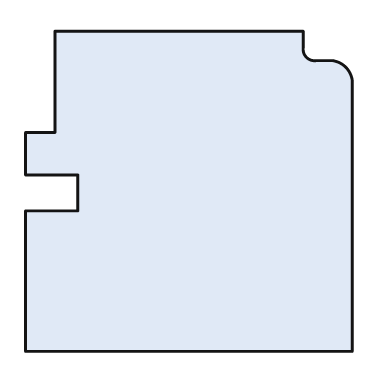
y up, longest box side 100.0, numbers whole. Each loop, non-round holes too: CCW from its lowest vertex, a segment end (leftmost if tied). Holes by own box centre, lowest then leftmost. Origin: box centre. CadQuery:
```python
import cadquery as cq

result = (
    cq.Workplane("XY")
    .moveTo(-50.0, -49.0)
    .lineTo(50.0, -49.0)
    .lineTo(50.0, 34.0)
    .threePointArc((48.0, 38.0), (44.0, 40.0))
    .lineTo(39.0, 40.0)
    .threePointArc((36.0, 41.0), (35.0, 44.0))
    .lineTo(35.0, 49.0)
    .lineTo(-41.0, 49.0)
    .lineTo(-41.0, 18.0)
    .lineTo(-50.0, 18.0)
    .lineTo(-50.0, 5.0)
    .lineTo(-34.0, 5.0)
    .lineTo(-34.0, -6.0)
    .lineTo(-50.0, -6.0)
    .close()
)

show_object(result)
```